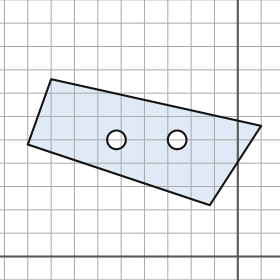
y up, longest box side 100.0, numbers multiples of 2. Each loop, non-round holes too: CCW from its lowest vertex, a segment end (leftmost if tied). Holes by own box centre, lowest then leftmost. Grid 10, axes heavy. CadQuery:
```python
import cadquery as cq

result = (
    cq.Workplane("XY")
    .moveTo(-12.0, 22.0)
    .lineTo(10.0, 56.0)
    .lineTo(-80.0, 76.0)
    .lineTo(-90.0, 48.0)
    .close()
    .moveTo(-52.0, 50.0)
    .circle(4.0)
    .moveTo(-26.0, 50.0)
    .circle(4.0)
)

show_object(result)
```